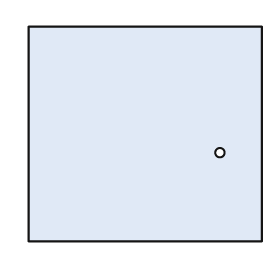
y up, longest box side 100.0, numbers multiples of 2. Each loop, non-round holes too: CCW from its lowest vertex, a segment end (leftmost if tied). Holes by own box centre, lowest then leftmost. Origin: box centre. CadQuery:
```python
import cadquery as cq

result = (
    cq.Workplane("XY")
    .moveTo(-50.0, -46.0)
    .lineTo(50.0, -46.0)
    .lineTo(50.0, 46.0)
    .lineTo(-50.0, 46.0)
    .close()
    .moveTo(32.0, -8.0)
    .circle(2.0)
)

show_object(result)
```